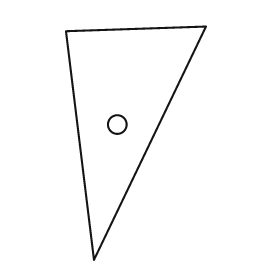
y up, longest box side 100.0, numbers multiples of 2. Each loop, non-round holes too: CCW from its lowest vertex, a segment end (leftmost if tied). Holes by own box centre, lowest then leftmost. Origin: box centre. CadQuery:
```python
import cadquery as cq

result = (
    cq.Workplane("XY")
    .moveTo(-18.0, -50.0)
    .lineTo(30.0, 50.0)
    .lineTo(-30.0, 48.0)
    .close()
    .moveTo(-8.0, 8.0)
    .circle(4.0)
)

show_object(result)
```